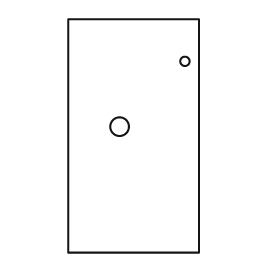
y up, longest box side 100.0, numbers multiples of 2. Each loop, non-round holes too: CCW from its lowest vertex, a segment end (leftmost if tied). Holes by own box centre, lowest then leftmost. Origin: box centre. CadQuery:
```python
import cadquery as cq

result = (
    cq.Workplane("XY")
    .moveTo(-28.0, -50.0)
    .lineTo(28.0, -50.0)
    .lineTo(28.0, 50.0)
    .lineTo(-28.0, 50.0)
    .close()
    .moveTo(-6.0, 4.0)
    .circle(4.0)
    .moveTo(22.0, 32.0)
    .circle(2.0)
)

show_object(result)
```